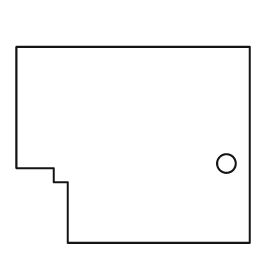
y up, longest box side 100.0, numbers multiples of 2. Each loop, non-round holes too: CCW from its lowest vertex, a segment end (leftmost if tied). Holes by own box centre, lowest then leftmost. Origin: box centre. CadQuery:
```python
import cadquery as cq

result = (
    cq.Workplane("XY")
    .moveTo(-28.0, -42.0)
    .lineTo(50.0, -42.0)
    .lineTo(50.0, 42.0)
    .lineTo(-50.0, 42.0)
    .lineTo(-50.0, -10.0)
    .lineTo(-34.0, -10.0)
    .lineTo(-34.0, -16.0)
    .lineTo(-28.0, -16.0)
    .close()
    .moveTo(40.0, -8.0)
    .circle(4.0)
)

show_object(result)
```